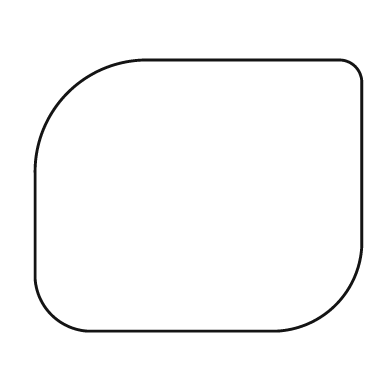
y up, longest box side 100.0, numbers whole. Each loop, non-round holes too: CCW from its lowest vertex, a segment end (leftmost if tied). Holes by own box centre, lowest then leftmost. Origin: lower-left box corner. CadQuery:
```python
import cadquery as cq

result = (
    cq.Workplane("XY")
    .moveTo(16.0, 0.0)
    .lineTo(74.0, 0.0)
    .threePointArc((92.0, 8.0), (100.0, 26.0))
    .lineTo(100.0, 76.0)
    .threePointArc((98.0, 81.0), (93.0, 83.0))
    .lineTo(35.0, 83.0)
    .threePointArc((10.0, 73.0), (0.0, 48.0))
    .lineTo(0.0, 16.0)
    .threePointArc((5.0, 5.0), (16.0, 0.0))
    .close()
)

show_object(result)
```